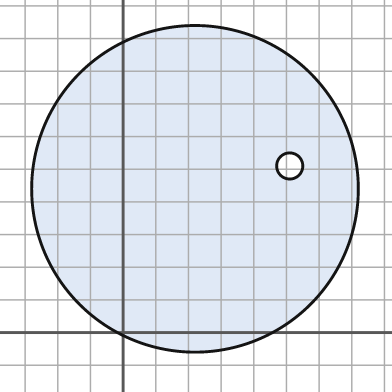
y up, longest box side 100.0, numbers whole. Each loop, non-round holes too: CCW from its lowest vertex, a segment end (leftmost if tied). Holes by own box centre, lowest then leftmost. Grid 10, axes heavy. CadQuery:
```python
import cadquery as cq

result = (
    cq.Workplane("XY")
    .moveTo(22.0, 44.0)
    .circle(50.0)
    .moveTo(51.0, 51.0)
    .circle(4.0)
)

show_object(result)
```